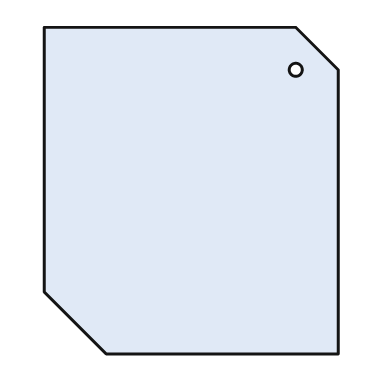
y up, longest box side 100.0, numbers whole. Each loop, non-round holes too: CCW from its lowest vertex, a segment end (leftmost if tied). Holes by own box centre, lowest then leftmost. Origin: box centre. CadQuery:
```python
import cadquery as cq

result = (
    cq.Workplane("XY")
    .moveTo(-26.0, -50.0)
    .lineTo(45.0, -50.0)
    .lineTo(45.0, 37.0)
    .lineTo(32.0, 50.0)
    .lineTo(-45.0, 50.0)
    .lineTo(-45.0, -31.0)
    .close()
    .moveTo(32.0, 37.0)
    .circle(2.0)
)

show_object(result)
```